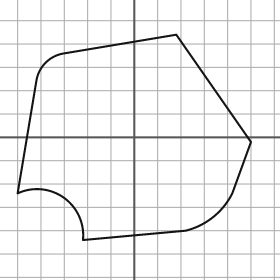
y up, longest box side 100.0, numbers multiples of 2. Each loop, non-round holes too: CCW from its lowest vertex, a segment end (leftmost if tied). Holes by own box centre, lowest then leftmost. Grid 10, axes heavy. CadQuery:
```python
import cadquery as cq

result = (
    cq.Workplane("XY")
    .moveTo(-22.0, -44.0)
    .lineTo(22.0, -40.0)
    .threePointArc((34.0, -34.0), (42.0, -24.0))
    .lineTo(50.0, -2.0)
    .lineTo(18.0, 44.0)
    .lineTo(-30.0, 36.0)
    .threePointArc((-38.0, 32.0), (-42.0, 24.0))
    .lineTo(-50.0, -24.0)
    .threePointArc((-30.0, -26.0), (-22.0, -44.0))
    .close()
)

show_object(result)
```